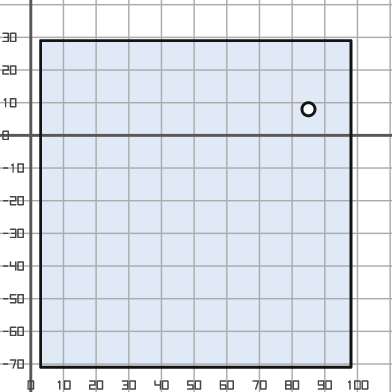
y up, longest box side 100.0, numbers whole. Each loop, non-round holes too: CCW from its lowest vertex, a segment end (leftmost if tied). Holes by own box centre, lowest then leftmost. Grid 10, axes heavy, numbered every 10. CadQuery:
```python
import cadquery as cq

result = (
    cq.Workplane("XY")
    .moveTo(3.0, -71.0)
    .lineTo(98.0, -71.0)
    .lineTo(98.0, 29.0)
    .lineTo(3.0, 29.0)
    .close()
    .moveTo(85.0, 8.0)
    .circle(2.0)
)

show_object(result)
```